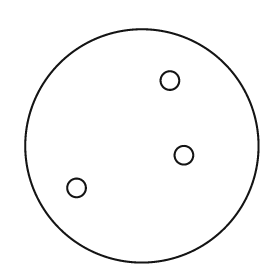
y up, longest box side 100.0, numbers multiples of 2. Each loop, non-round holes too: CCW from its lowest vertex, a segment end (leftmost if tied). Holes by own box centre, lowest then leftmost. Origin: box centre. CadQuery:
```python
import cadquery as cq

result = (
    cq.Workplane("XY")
    .moveTo(0.0, 0.0)
    .circle(50.0)
    .moveTo(-28.0, -18.0)
    .circle(4.0)
    .moveTo(18.0, -4.0)
    .circle(4.0)
    .moveTo(12.0, 28.0)
    .circle(4.0)
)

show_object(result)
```